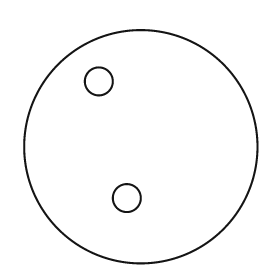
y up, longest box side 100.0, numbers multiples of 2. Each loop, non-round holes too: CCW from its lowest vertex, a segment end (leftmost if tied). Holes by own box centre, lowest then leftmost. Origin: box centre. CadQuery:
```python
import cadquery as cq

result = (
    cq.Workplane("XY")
    .moveTo(0.0, 0.0)
    .circle(50.0)
    .moveTo(-6.0, -22.0)
    .circle(6.0)
    .moveTo(-18.0, 28.0)
    .circle(6.0)
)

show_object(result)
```